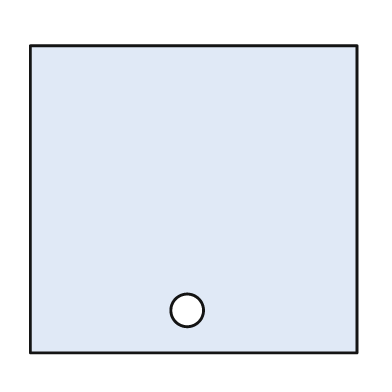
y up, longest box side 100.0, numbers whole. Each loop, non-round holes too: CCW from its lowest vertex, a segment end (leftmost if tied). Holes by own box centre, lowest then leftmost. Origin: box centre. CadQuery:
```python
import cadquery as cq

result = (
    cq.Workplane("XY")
    .moveTo(-50.0, -47.0)
    .lineTo(50.0, -47.0)
    .lineTo(50.0, 47.0)
    .lineTo(-50.0, 47.0)
    .close()
    .moveTo(-2.0, -34.0)
    .circle(5.0)
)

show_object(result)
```